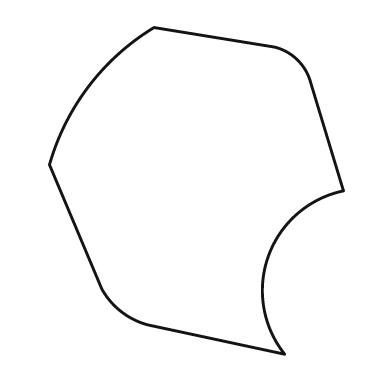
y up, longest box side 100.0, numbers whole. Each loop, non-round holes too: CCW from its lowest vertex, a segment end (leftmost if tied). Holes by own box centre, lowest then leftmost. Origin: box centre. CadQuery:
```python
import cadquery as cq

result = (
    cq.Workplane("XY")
    .moveTo(27.0, -50.0)
    .threePointArc((22.0, -20.0), (45.0, 0.0))
    .lineTo(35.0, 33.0)
    .threePointArc((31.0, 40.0), (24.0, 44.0))
    .lineTo(-13.0, 50.0)
    .threePointArc((-33.0, 32.0), (-45.0, 8.0))
    .lineTo(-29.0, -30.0)
    .threePointArc((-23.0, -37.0), (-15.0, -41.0))
    .close()
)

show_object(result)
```